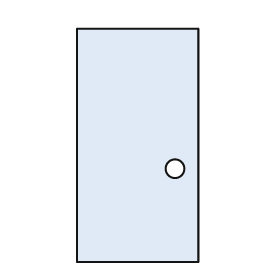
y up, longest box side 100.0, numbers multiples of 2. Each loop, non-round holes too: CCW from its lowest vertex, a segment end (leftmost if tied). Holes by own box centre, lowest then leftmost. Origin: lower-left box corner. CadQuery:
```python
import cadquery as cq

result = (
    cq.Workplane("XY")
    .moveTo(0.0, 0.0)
    .lineTo(52.0, 0.0)
    .lineTo(52.0, 100.0)
    .lineTo(0.0, 100.0)
    .close()
    .moveTo(42.0, 40.0)
    .circle(4.0)
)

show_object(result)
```